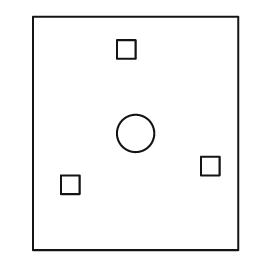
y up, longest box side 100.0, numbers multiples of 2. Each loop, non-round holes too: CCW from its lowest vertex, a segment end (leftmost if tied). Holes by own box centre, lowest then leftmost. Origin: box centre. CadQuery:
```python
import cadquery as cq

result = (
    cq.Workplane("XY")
    .moveTo(-44.0, -50.0)
    .lineTo(44.0, -50.0)
    .lineTo(44.0, 50.0)
    .lineTo(-44.0, 50.0)
    .close()
    .moveTo(-32.0, -26.0)
    .lineTo(-24.0, -26.0)
    .lineTo(-24.0, -18.0)
    .lineTo(-32.0, -18.0)
    .close()
    .moveTo(28.0, -18.0)
    .lineTo(36.0, -18.0)
    .lineTo(36.0, -10.0)
    .lineTo(28.0, -10.0)
    .close()
    .moveTo(0.0, 0.0)
    .circle(8.0)
    .moveTo(-8.0, 32.0)
    .lineTo(0.0, 32.0)
    .lineTo(0.0, 40.0)
    .lineTo(-8.0, 40.0)
    .close()
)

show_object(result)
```